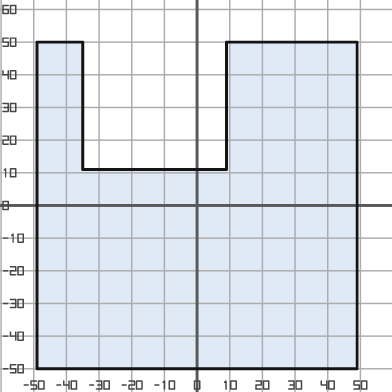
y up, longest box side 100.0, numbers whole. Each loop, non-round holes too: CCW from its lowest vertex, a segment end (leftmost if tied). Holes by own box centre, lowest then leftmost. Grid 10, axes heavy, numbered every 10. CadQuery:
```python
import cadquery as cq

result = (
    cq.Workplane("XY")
    .moveTo(-49.0, -50.0)
    .lineTo(49.0, -50.0)
    .lineTo(49.0, 50.0)
    .lineTo(9.0, 50.0)
    .lineTo(9.0, 11.0)
    .lineTo(-35.0, 11.0)
    .lineTo(-35.0, 50.0)
    .lineTo(-49.0, 50.0)
    .close()
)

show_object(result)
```